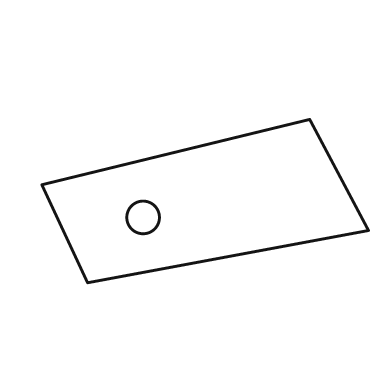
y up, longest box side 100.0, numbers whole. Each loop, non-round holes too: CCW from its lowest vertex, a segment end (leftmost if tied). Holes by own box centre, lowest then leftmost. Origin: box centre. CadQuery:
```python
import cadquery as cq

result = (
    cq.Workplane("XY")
    .moveTo(-36.0, -25.0)
    .lineTo(50.0, -9.0)
    .lineTo(32.0, 25.0)
    .lineTo(-50.0, 5.0)
    .close()
    .moveTo(-19.0, -5.0)
    .circle(5.0)
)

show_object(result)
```